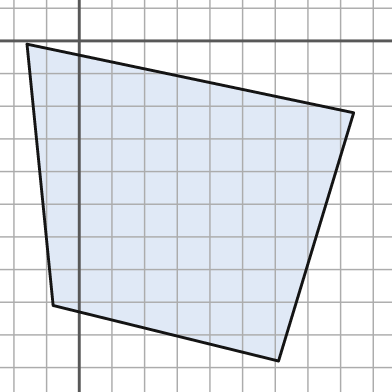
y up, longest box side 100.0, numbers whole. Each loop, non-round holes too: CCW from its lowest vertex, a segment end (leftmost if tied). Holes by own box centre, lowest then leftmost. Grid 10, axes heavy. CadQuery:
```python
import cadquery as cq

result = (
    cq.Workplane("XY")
    .moveTo(61.0, -98.0)
    .lineTo(84.0, -22.0)
    .lineTo(-16.0, -1.0)
    .lineTo(-8.0, -81.0)
    .close()
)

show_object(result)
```